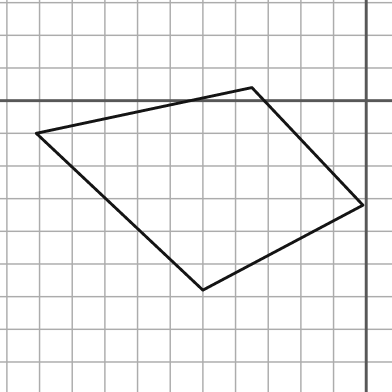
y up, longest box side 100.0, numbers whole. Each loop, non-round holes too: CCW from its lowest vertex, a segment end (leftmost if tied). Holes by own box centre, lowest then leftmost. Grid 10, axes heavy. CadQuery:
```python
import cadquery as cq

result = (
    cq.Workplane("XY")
    .moveTo(-50.0, -58.0)
    .lineTo(-1.0, -32.0)
    .lineTo(-35.0, 4.0)
    .lineTo(-101.0, -10.0)
    .close()
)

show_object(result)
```